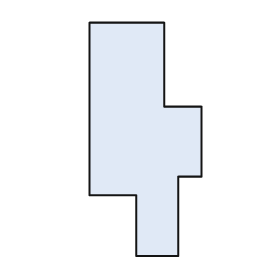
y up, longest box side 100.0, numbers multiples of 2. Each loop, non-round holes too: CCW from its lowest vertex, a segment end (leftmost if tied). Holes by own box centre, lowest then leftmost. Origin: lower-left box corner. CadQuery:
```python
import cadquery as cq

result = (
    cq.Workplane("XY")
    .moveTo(20.0, 0.0)
    .lineTo(38.0, 0.0)
    .lineTo(38.0, 34.0)
    .lineTo(48.0, 34.0)
    .lineTo(48.0, 64.0)
    .lineTo(32.0, 64.0)
    .lineTo(32.0, 100.0)
    .lineTo(0.0, 100.0)
    .lineTo(0.0, 26.0)
    .lineTo(20.0, 26.0)
    .close()
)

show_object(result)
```